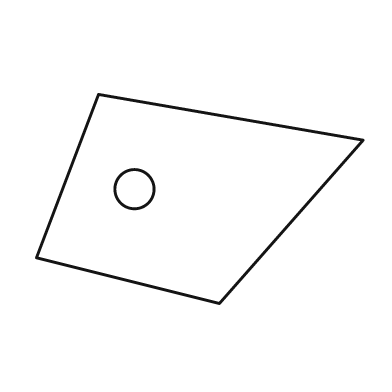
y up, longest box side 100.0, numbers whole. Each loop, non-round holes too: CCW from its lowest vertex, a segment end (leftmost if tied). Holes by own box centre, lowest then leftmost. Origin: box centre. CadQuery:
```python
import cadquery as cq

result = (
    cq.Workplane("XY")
    .moveTo(6.0, -32.0)
    .lineTo(50.0, 18.0)
    .lineTo(-31.0, 32.0)
    .lineTo(-50.0, -18.0)
    .close()
    .moveTo(-20.0, 3.0)
    .circle(6.0)
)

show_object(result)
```